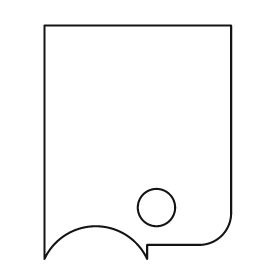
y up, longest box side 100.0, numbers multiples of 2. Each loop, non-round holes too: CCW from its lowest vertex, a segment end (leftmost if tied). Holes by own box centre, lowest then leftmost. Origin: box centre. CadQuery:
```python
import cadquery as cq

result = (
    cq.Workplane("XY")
    .moveTo(-40.0, -50.0)
    .threePointArc((-18.0, -36.0), (4.0, -50.0))
    .lineTo(4.0, -44.0)
    .lineTo(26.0, -44.0)
    .threePointArc((36.0, -40.0), (40.0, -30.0))
    .lineTo(40.0, 50.0)
    .lineTo(-40.0, 50.0)
    .close()
    .moveTo(8.0, -28.0)
    .circle(8.0)
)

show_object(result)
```